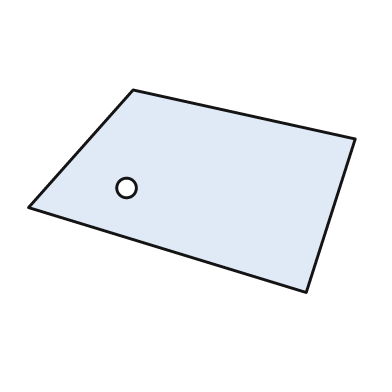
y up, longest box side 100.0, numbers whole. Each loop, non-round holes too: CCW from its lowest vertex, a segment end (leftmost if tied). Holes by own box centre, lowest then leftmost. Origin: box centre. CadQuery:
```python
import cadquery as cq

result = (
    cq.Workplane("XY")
    .moveTo(35.0, -31.0)
    .lineTo(50.0, 16.0)
    .lineTo(-18.0, 31.0)
    .lineTo(-50.0, -5.0)
    .close()
    .moveTo(-20.0, 1.0)
    .circle(3.0)
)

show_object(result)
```